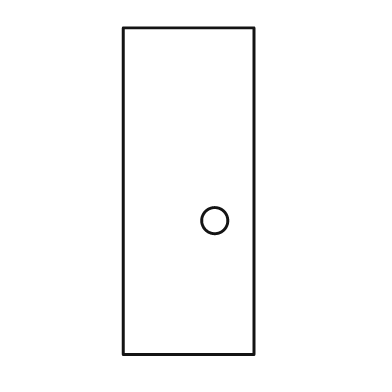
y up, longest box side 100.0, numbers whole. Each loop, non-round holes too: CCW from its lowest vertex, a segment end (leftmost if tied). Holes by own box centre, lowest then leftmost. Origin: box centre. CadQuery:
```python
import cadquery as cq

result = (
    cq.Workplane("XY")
    .moveTo(-20.0, -50.0)
    .lineTo(20.0, -50.0)
    .lineTo(20.0, 50.0)
    .lineTo(-20.0, 50.0)
    .close()
    .moveTo(8.0, -9.0)
    .circle(4.0)
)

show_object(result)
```